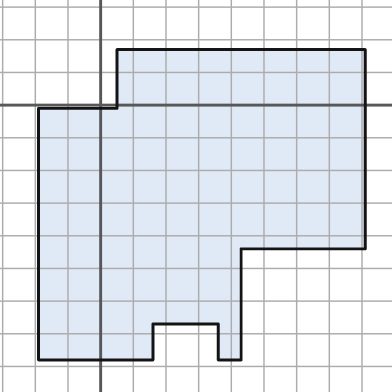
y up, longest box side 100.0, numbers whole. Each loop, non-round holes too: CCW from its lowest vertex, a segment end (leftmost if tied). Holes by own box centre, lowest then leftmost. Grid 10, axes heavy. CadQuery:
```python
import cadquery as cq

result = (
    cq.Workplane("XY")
    .moveTo(-19.0, -78.0)
    .lineTo(16.0, -78.0)
    .lineTo(16.0, -67.0)
    .lineTo(36.0, -67.0)
    .lineTo(36.0, -78.0)
    .lineTo(43.0, -78.0)
    .lineTo(43.0, -44.0)
    .lineTo(81.0, -44.0)
    .lineTo(81.0, 17.0)
    .lineTo(5.0, 17.0)
    .lineTo(5.0, -1.0)
    .lineTo(-19.0, -1.0)
    .close()
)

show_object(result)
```